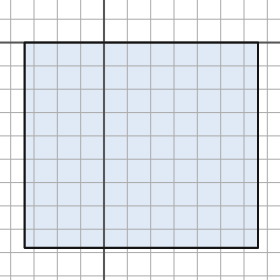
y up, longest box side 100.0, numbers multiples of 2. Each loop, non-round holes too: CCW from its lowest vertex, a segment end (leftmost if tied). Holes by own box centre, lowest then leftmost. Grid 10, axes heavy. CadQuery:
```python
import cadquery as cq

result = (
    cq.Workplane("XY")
    .moveTo(-34.0, -88.0)
    .lineTo(66.0, -88.0)
    .lineTo(66.0, 0.0)
    .lineTo(-34.0, 0.0)
    .close()
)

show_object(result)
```